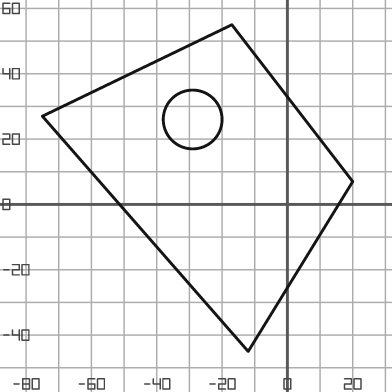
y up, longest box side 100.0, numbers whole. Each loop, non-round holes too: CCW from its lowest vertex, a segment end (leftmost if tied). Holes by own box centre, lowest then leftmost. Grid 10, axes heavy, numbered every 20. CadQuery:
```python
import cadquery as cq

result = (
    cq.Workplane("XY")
    .moveTo(-12.0, -45.0)
    .lineTo(20.0, 7.0)
    .lineTo(-17.0, 55.0)
    .lineTo(-75.0, 27.0)
    .close()
    .moveTo(-29.0, 26.0)
    .circle(9.0)
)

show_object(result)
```